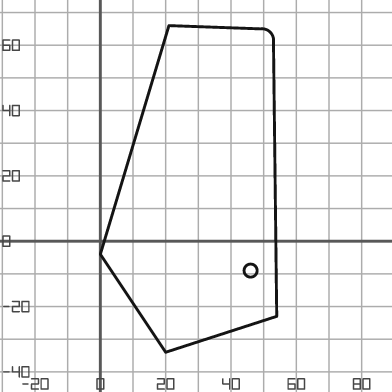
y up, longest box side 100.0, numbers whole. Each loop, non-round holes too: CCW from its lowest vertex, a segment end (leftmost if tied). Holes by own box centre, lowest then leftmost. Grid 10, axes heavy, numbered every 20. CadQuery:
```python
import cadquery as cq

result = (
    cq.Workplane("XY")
    .moveTo(20.0, -34.0)
    .lineTo(54.0, -23.0)
    .lineTo(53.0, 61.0)
    .threePointArc((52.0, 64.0), (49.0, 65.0))
    .lineTo(21.0, 66.0)
    .lineTo(0.0, -4.0)
    .close()
    .moveTo(46.0, -9.0)
    .circle(2.0)
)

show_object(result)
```